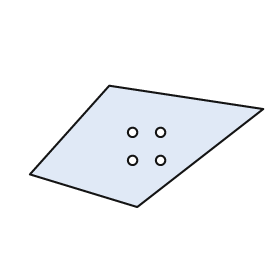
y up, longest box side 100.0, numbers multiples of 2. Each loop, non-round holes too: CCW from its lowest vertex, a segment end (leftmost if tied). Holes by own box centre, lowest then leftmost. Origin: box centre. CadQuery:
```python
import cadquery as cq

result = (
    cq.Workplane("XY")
    .moveTo(-4.0, -26.0)
    .lineTo(50.0, 16.0)
    .lineTo(-16.0, 26.0)
    .lineTo(-50.0, -12.0)
    .close()
    .moveTo(-6.0, -6.0)
    .circle(2.0)
    .moveTo(6.0, -6.0)
    .circle(2.0)
    .moveTo(-6.0, 6.0)
    .circle(2.0)
    .moveTo(6.0, 6.0)
    .circle(2.0)
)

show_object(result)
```